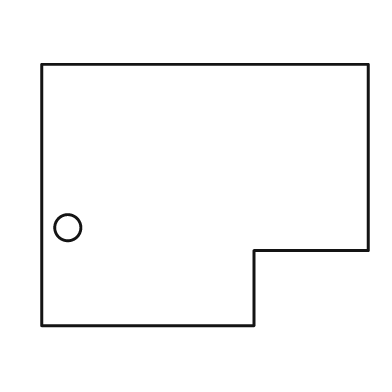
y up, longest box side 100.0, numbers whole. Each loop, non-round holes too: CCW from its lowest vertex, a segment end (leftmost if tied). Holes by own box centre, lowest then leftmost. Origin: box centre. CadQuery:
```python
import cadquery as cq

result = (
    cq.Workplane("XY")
    .moveTo(-50.0, -40.0)
    .lineTo(15.0, -40.0)
    .lineTo(15.0, -17.0)
    .lineTo(50.0, -17.0)
    .lineTo(50.0, 40.0)
    .lineTo(-50.0, 40.0)
    .close()
    .moveTo(-42.0, -10.0)
    .circle(4.0)
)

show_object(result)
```